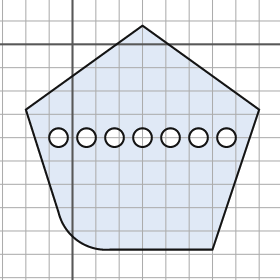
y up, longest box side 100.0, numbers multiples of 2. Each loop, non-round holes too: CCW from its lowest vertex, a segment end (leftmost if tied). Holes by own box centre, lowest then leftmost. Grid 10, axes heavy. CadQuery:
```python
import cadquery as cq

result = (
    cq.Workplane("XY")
    .moveTo(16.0, -88.0)
    .lineTo(60.0, -88.0)
    .lineTo(80.0, -28.0)
    .lineTo(30.0, 8.0)
    .lineTo(-20.0, -28.0)
    .lineTo(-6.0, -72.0)
    .threePointArc((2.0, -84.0), (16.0, -88.0))
    .close()
    .moveTo(-6.0, -40.0)
    .circle(4.0)
    .moveTo(6.0, -40.0)
    .circle(4.0)
    .moveTo(18.0, -40.0)
    .circle(4.0)
    .moveTo(30.0, -40.0)
    .circle(4.0)
    .moveTo(42.0, -40.0)
    .circle(4.0)
    .moveTo(54.0, -40.0)
    .circle(4.0)
    .moveTo(66.0, -40.0)
    .circle(4.0)
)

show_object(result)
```